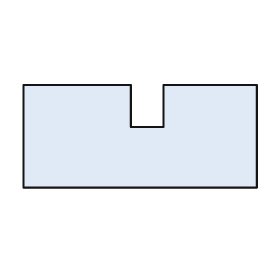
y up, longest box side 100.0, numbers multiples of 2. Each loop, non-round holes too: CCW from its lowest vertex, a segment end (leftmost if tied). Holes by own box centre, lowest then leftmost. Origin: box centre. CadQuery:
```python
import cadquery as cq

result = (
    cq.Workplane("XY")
    .moveTo(-50.0, -22.0)
    .lineTo(50.0, -22.0)
    .lineTo(50.0, 22.0)
    .lineTo(10.0, 22.0)
    .lineTo(10.0, 4.0)
    .lineTo(-4.0, 4.0)
    .lineTo(-4.0, 22.0)
    .lineTo(-50.0, 22.0)
    .close()
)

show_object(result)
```